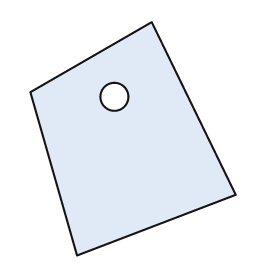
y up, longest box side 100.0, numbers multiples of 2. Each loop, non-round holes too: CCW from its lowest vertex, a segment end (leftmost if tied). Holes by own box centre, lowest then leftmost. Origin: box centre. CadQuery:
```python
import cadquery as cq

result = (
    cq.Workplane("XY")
    .moveTo(-24.0, -50.0)
    .lineTo(44.0, -24.0)
    .lineTo(8.0, 50.0)
    .lineTo(-44.0, 20.0)
    .close()
    .moveTo(-8.0, 18.0)
    .circle(6.0)
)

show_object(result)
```